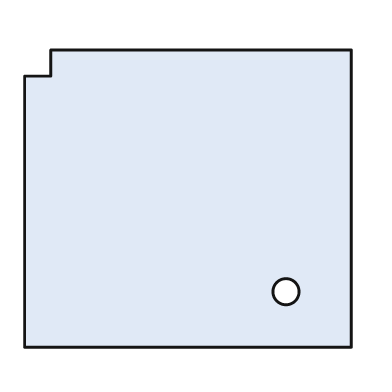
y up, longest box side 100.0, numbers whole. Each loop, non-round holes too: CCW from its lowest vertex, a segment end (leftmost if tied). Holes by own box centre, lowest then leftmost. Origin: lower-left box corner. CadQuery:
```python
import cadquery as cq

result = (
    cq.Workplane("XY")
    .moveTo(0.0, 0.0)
    .lineTo(100.0, 0.0)
    .lineTo(100.0, 91.0)
    .lineTo(8.0, 91.0)
    .lineTo(8.0, 83.0)
    .lineTo(0.0, 83.0)
    .close()
    .moveTo(80.0, 17.0)
    .circle(4.0)
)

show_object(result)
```